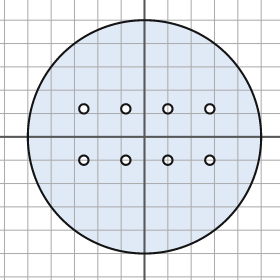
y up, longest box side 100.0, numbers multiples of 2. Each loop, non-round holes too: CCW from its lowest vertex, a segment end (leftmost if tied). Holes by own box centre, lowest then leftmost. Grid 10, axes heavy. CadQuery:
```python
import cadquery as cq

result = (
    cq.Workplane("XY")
    .moveTo(0.0, 0.0)
    .circle(50.0)
    .moveTo(-26.0, -10.0)
    .circle(2.0)
    .moveTo(-8.0, -10.0)
    .circle(2.0)
    .moveTo(10.0, -10.0)
    .circle(2.0)
    .moveTo(28.0, -10.0)
    .circle(2.0)
    .moveTo(-26.0, 12.0)
    .circle(2.0)
    .moveTo(-8.0, 12.0)
    .circle(2.0)
    .moveTo(10.0, 12.0)
    .circle(2.0)
    .moveTo(28.0, 12.0)
    .circle(2.0)
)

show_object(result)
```